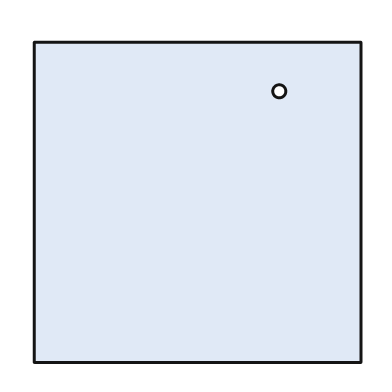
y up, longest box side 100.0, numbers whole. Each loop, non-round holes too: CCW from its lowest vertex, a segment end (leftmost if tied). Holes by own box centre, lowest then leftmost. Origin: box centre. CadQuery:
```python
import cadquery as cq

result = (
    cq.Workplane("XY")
    .moveTo(-50.0, -49.0)
    .lineTo(50.0, -49.0)
    .lineTo(50.0, 49.0)
    .lineTo(-50.0, 49.0)
    .close()
    .moveTo(25.0, 34.0)
    .circle(2.0)
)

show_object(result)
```